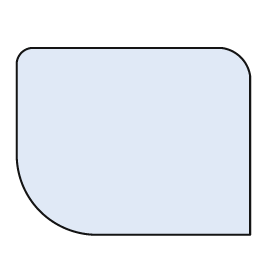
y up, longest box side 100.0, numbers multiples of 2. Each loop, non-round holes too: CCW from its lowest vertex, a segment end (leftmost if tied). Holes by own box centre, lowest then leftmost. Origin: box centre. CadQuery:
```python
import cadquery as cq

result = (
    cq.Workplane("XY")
    .moveTo(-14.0, -40.0)
    .lineTo(50.0, -40.0)
    .lineTo(50.0, 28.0)
    .threePointArc((46.0, 36.0), (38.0, 40.0))
    .lineTo(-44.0, 40.0)
    .threePointArc((-48.0, 38.0), (-50.0, 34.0))
    .lineTo(-50.0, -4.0)
    .threePointArc((-40.0, -30.0), (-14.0, -40.0))
    .close()
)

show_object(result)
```